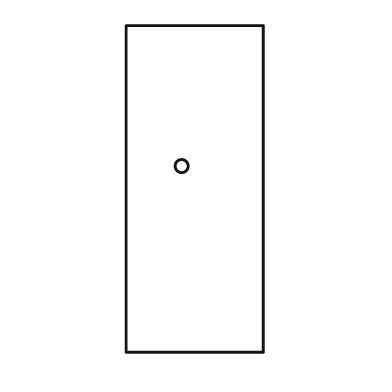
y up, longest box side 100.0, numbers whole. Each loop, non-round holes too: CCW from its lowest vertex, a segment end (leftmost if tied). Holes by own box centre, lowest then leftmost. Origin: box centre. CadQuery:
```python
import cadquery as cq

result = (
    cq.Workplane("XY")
    .moveTo(-21.0, -50.0)
    .lineTo(21.0, -50.0)
    .lineTo(21.0, 50.0)
    .lineTo(-21.0, 50.0)
    .close()
    .moveTo(-4.0, 7.0)
    .circle(2.0)
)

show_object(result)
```